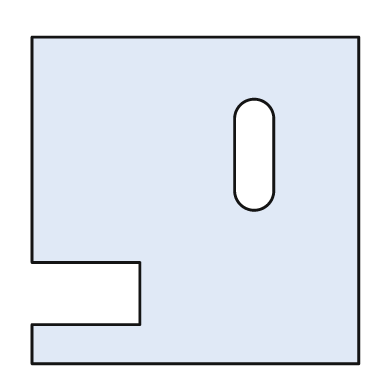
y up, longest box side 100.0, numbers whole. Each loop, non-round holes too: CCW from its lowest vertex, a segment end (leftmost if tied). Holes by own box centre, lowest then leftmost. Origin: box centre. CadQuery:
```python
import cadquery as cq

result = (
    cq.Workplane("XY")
    .moveTo(-50.0, -50.0)
    .lineTo(50.0, -50.0)
    .lineTo(50.0, 50.0)
    .lineTo(-50.0, 50.0)
    .lineTo(-50.0, -19.0)
    .lineTo(-17.0, -19.0)
    .lineTo(-17.0, -38.0)
    .lineTo(-50.0, -38.0)
    .close()
    .moveTo(12.0, 3.0)
    .threePointArc((18.0, -3.0), (24.0, 3.0))
    .lineTo(24.0, 25.0)
    .threePointArc((18.0, 31.0), (12.0, 25.0))
    .close()
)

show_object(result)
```